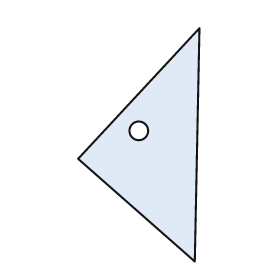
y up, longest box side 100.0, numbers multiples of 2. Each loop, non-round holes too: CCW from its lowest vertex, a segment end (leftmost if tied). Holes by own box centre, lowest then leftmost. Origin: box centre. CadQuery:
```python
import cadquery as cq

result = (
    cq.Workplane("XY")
    .moveTo(24.0, -50.0)
    .lineTo(26.0, 50.0)
    .lineTo(-26.0, -6.0)
    .close()
    .moveTo(0.0, 6.0)
    .circle(4.0)
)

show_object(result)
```